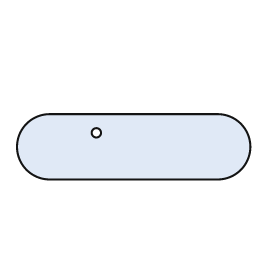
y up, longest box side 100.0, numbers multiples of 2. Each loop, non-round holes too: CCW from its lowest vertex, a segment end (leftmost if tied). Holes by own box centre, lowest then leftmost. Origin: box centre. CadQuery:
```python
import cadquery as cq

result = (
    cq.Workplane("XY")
    .moveTo(-36.0, -14.0)
    .lineTo(36.0, -14.0)
    .threePointArc((50.0, 0.0), (36.0, 14.0))
    .lineTo(-36.0, 14.0)
    .threePointArc((-50.0, 0.0), (-36.0, -14.0))
    .close()
    .moveTo(-16.0, 6.0)
    .circle(2.0)
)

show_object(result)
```